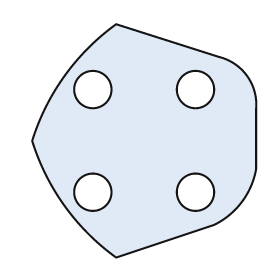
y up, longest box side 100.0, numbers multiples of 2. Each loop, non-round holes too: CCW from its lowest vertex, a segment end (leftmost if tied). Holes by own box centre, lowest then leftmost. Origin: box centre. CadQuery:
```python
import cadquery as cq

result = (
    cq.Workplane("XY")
    .moveTo(-12.0, -50.0)
    .lineTo(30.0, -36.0)
    .threePointArc((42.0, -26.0), (48.0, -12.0))
    .lineTo(48.0, 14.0)
    .threePointArc((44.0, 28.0), (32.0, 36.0))
    .lineTo(-12.0, 50.0)
    .threePointArc((-34.0, 28.0), (-48.0, 0.0))
    .threePointArc((-34.0, -28.0), (-12.0, -50.0))
    .close()
    .moveTo(-22.0, -22.0)
    .circle(8.0)
    .moveTo(22.0, -22.0)
    .circle(8.0)
    .moveTo(-22.0, 22.0)
    .circle(8.0)
    .moveTo(22.0, 22.0)
    .circle(8.0)
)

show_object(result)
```